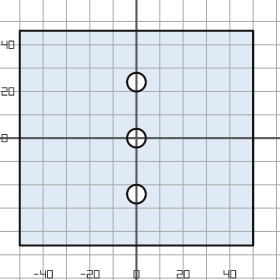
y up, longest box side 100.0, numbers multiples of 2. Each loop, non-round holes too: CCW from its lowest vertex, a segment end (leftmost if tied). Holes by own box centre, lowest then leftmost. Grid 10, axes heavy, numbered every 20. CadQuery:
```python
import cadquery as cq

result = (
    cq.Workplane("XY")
    .moveTo(-50.0, -46.0)
    .lineTo(50.0, -46.0)
    .lineTo(50.0, 46.0)
    .lineTo(-50.0, 46.0)
    .close()
    .moveTo(0.0, -24.0)
    .circle(4.0)
    .moveTo(0.0, 0.0)
    .circle(4.0)
    .moveTo(0.0, 24.0)
    .circle(4.0)
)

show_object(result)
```